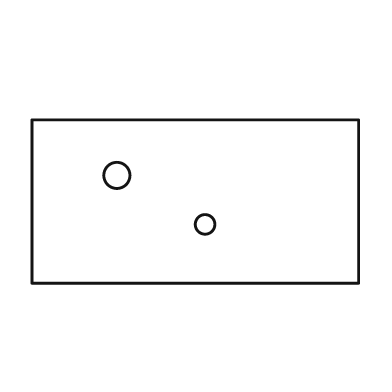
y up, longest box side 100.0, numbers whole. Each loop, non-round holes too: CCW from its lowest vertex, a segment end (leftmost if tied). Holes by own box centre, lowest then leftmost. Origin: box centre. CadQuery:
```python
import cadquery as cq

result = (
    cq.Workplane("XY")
    .moveTo(-50.0, -25.0)
    .lineTo(50.0, -25.0)
    .lineTo(50.0, 25.0)
    .lineTo(-50.0, 25.0)
    .close()
    .moveTo(3.0, -7.0)
    .circle(3.0)
    .moveTo(-24.0, 8.0)
    .circle(4.0)
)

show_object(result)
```